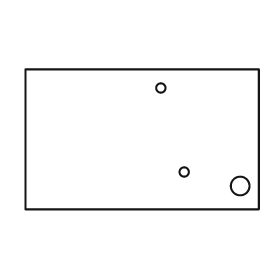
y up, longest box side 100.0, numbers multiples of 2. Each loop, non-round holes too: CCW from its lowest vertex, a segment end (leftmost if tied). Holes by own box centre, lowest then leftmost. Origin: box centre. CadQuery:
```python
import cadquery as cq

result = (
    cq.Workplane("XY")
    .moveTo(-50.0, -30.0)
    .lineTo(50.0, -30.0)
    .lineTo(50.0, 30.0)
    .lineTo(-50.0, 30.0)
    .close()
    .moveTo(42.0, -20.0)
    .circle(4.0)
    .moveTo(18.0, -14.0)
    .circle(2.0)
    .moveTo(8.0, 22.0)
    .circle(2.0)
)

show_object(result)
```